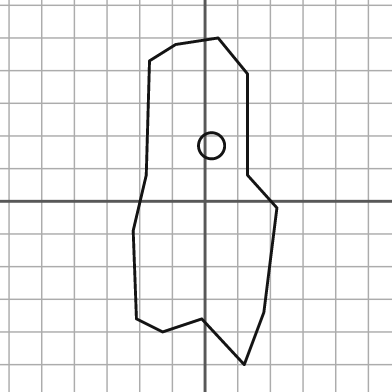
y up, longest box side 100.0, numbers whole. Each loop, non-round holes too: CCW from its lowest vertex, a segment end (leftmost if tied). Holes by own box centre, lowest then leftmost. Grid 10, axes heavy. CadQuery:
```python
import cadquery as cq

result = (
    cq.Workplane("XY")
    .moveTo(12.0, -50.0)
    .lineTo(18.0, -34.0)
    .lineTo(22.0, -2.0)
    .lineTo(13.0, 8.0)
    .lineTo(13.0, 39.0)
    .lineTo(4.0, 50.0)
    .lineTo(-9.0, 48.0)
    .lineTo(-17.0, 43.0)
    .lineTo(-18.0, 8.0)
    .lineTo(-22.0, -9.0)
    .lineTo(-21.0, -36.0)
    .lineTo(-13.0, -40.0)
    .lineTo(-1.0, -36.0)
    .close()
    .moveTo(2.0, 17.0)
    .circle(4.0)
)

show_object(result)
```